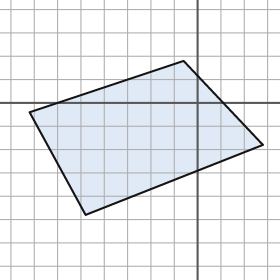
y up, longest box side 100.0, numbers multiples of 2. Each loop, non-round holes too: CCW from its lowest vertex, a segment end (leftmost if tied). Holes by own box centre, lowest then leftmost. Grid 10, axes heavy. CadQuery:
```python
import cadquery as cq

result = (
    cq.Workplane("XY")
    .moveTo(-48.0, -48.0)
    .lineTo(28.0, -18.0)
    .lineTo(-6.0, 18.0)
    .lineTo(-72.0, -4.0)
    .close()
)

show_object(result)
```